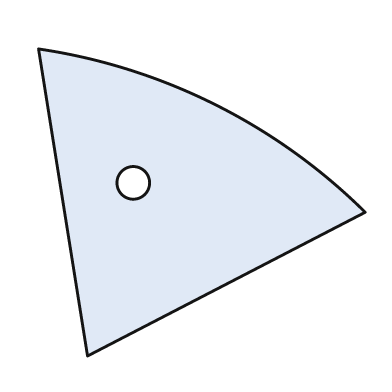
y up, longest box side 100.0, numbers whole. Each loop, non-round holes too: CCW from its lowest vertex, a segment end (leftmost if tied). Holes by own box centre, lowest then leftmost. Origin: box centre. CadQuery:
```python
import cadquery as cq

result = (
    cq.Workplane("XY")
    .moveTo(-35.0, -47.0)
    .lineTo(50.0, -3.0)
    .threePointArc((4.0, 30.0), (-50.0, 47.0))
    .close()
    .moveTo(-21.0, 6.0)
    .circle(5.0)
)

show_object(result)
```